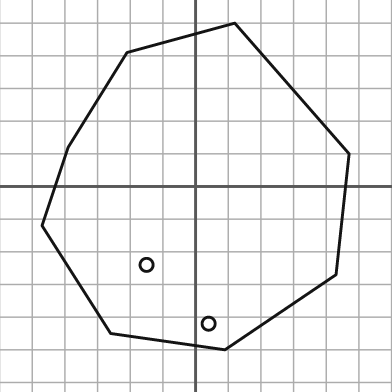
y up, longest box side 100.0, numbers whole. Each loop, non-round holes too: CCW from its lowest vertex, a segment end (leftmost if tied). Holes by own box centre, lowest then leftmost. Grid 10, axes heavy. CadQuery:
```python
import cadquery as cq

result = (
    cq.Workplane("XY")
    .moveTo(9.0, -50.0)
    .lineTo(43.0, -27.0)
    .lineTo(47.0, 10.0)
    .lineTo(12.0, 50.0)
    .lineTo(-21.0, 41.0)
    .lineTo(-39.0, 12.0)
    .lineTo(-47.0, -12.0)
    .lineTo(-26.0, -45.0)
    .close()
    .moveTo(4.0, -42.0)
    .circle(2.0)
    .moveTo(-15.0, -24.0)
    .circle(2.0)
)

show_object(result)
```